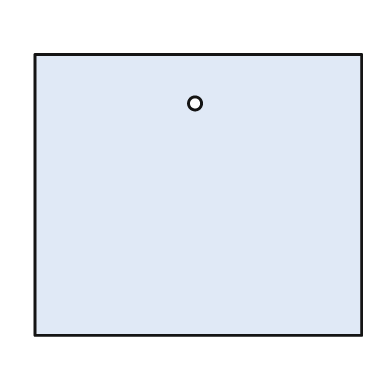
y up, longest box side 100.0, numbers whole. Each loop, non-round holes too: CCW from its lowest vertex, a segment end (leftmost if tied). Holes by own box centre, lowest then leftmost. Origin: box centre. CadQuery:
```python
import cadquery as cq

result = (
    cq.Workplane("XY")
    .moveTo(-50.0, -43.0)
    .lineTo(50.0, -43.0)
    .lineTo(50.0, 43.0)
    .lineTo(-50.0, 43.0)
    .close()
    .moveTo(-1.0, 28.0)
    .circle(2.0)
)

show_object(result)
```